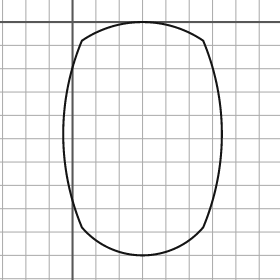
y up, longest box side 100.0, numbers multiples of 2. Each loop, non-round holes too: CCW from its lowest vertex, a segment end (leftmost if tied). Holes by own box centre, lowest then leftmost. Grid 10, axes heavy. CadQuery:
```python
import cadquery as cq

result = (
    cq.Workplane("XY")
    .moveTo(4.0, -88.0)
    .threePointArc((30.0, -100.0), (56.0, -88.0))
    .threePointArc((64.0, -48.0), (56.0, -8.0))
    .threePointArc((30.0, 0.0), (4.0, -8.0))
    .threePointArc((-4.0, -48.0), (4.0, -88.0))
    .close()
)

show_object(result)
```